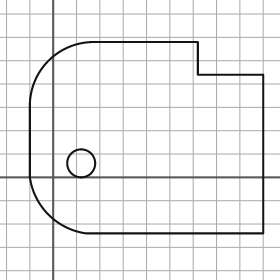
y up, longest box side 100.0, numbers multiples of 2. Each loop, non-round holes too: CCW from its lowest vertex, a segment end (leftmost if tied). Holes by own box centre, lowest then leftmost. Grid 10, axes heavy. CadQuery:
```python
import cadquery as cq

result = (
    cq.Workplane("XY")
    .moveTo(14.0, -24.0)
    .lineTo(90.0, -24.0)
    .lineTo(90.0, 44.0)
    .lineTo(62.0, 44.0)
    .lineTo(62.0, 58.0)
    .lineTo(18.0, 58.0)
    .threePointArc((-2.0, 50.0), (-10.0, 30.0))
    .lineTo(-10.0, 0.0)
    .threePointArc((-2.0, -16.0), (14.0, -24.0))
    .close()
    .moveTo(12.0, 6.0)
    .circle(6.0)
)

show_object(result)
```